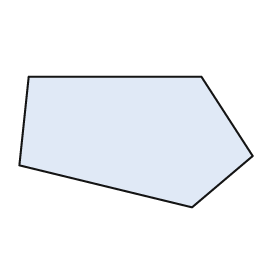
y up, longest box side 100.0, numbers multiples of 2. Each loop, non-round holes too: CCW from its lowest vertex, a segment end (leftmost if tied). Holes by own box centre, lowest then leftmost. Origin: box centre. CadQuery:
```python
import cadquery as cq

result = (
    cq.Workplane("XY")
    .moveTo(24.0, -28.0)
    .lineTo(50.0, -6.0)
    .lineTo(28.0, 28.0)
    .lineTo(-46.0, 28.0)
    .lineTo(-50.0, -10.0)
    .close()
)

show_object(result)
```